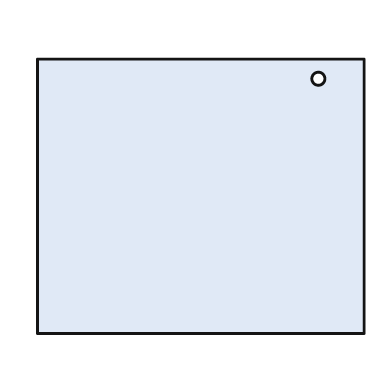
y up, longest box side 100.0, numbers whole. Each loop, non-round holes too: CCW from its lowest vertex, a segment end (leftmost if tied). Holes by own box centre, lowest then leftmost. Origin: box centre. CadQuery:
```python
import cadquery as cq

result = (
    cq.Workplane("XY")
    .moveTo(-50.0, -42.0)
    .lineTo(50.0, -42.0)
    .lineTo(50.0, 42.0)
    .lineTo(-50.0, 42.0)
    .close()
    .moveTo(36.0, 36.0)
    .circle(2.0)
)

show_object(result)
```